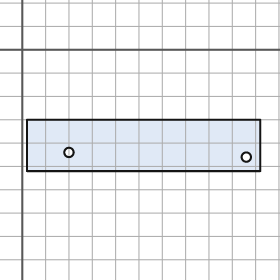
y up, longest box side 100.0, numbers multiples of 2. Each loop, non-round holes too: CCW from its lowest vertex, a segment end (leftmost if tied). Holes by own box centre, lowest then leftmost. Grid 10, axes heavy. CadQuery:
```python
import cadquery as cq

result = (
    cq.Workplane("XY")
    .moveTo(2.0, -52.0)
    .lineTo(102.0, -52.0)
    .lineTo(102.0, -30.0)
    .lineTo(2.0, -30.0)
    .close()
    .moveTo(96.0, -46.0)
    .circle(2.0)
    .moveTo(20.0, -44.0)
    .circle(2.0)
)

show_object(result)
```